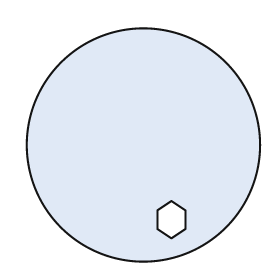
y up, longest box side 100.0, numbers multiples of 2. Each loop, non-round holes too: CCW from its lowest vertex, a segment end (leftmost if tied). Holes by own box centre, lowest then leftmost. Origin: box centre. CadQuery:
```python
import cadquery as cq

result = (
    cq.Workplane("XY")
    .moveTo(0.0, 0.0)
    .circle(50.0)
    .moveTo(12.0, -40.0)
    .lineTo(18.0, -36.0)
    .lineTo(18.0, -28.0)
    .lineTo(12.0, -24.0)
    .lineTo(6.0, -28.0)
    .lineTo(6.0, -36.0)
    .close()
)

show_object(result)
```